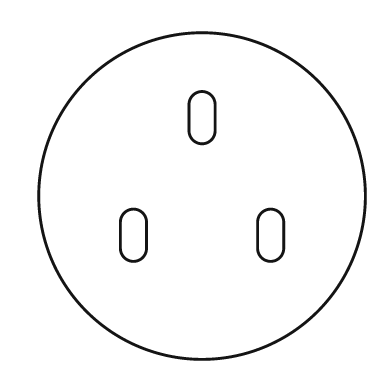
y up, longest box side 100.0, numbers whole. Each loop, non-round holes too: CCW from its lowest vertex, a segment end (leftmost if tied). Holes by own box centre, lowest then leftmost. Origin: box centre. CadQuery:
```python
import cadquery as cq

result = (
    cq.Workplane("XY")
    .moveTo(0.0, 0.0)
    .circle(50.0)
    .moveTo(-25.0, -16.0)
    .threePointArc((-21.0, -20.0), (-17.0, -16.0))
    .lineTo(-17.0, -8.0)
    .threePointArc((-21.0, -4.0), (-25.0, -8.0))
    .close()
    .moveTo(17.0, -16.0)
    .threePointArc((21.0, -20.0), (25.0, -16.0))
    .lineTo(25.0, -8.0)
    .threePointArc((21.0, -4.0), (17.0, -8.0))
    .close()
    .moveTo(-4.0, 20.0)
    .threePointArc((0.0, 16.0), (4.0, 20.0))
    .lineTo(4.0, 28.0)
    .threePointArc((0.0, 32.0), (-4.0, 28.0))
    .close()
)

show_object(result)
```